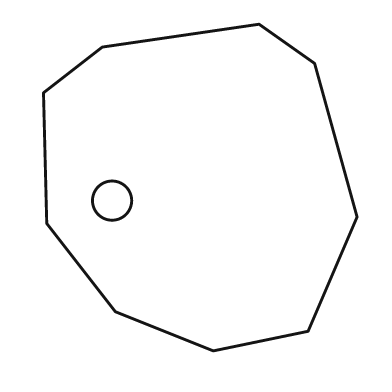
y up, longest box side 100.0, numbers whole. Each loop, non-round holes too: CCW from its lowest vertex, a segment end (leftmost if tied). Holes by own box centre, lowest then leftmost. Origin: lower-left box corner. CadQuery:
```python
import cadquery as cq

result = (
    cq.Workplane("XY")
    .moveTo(52.0, 0.0)
    .lineTo(81.0, 6.0)
    .lineTo(96.0, 41.0)
    .lineTo(83.0, 88.0)
    .lineTo(66.0, 100.0)
    .lineTo(18.0, 93.0)
    .lineTo(0.0, 79.0)
    .lineTo(1.0, 39.0)
    .lineTo(22.0, 12.0)
    .close()
    .moveTo(21.0, 46.0)
    .circle(6.0)
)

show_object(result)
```